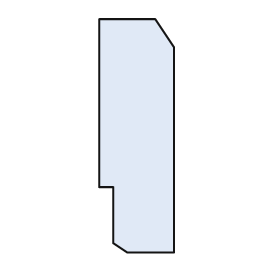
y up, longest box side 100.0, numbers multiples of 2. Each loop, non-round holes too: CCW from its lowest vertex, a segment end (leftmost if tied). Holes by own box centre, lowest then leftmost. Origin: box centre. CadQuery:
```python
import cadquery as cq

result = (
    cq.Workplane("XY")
    .moveTo(-4.0, -50.0)
    .lineTo(16.0, -50.0)
    .lineTo(16.0, 38.0)
    .lineTo(8.0, 50.0)
    .lineTo(-16.0, 50.0)
    .lineTo(-16.0, -22.0)
    .lineTo(-10.0, -22.0)
    .lineTo(-10.0, -46.0)
    .close()
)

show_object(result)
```